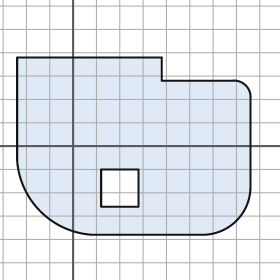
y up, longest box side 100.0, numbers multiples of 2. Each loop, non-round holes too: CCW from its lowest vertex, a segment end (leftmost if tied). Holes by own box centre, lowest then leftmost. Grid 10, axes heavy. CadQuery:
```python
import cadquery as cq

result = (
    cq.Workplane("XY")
    .moveTo(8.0, -38.0)
    .lineTo(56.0, -38.0)
    .threePointArc((70.0, -32.0), (76.0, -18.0))
    .lineTo(76.0, 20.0)
    .threePointArc((74.0, 26.0), (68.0, 28.0))
    .lineTo(38.0, 28.0)
    .lineTo(38.0, 38.0)
    .lineTo(-24.0, 38.0)
    .lineTo(-24.0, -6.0)
    .threePointArc((-14.0, -28.0), (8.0, -38.0))
    .close()
    .moveTo(12.0, -26.0)
    .lineTo(28.0, -26.0)
    .lineTo(28.0, -10.0)
    .lineTo(12.0, -10.0)
    .close()
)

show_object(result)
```